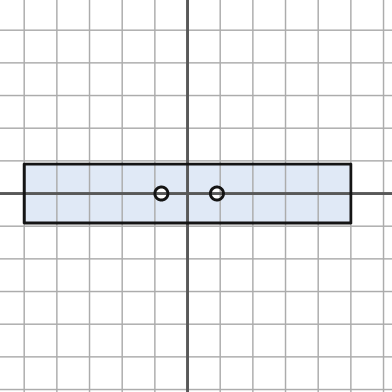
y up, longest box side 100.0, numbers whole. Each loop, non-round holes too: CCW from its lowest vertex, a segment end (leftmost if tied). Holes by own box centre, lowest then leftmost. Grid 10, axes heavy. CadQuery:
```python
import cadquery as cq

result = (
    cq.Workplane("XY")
    .moveTo(-50.0, -9.0)
    .lineTo(50.0, -9.0)
    .lineTo(50.0, 9.0)
    .lineTo(-50.0, 9.0)
    .close()
    .moveTo(-8.0, 0.0)
    .circle(2.0)
    .moveTo(9.0, 0.0)
    .circle(2.0)
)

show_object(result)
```